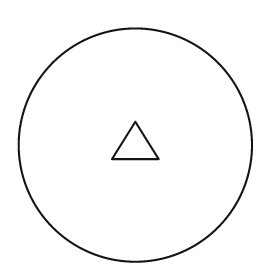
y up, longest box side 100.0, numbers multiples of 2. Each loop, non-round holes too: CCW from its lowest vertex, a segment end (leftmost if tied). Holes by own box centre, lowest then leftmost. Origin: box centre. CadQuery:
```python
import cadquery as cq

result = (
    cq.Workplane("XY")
    .moveTo(0.0, 0.0)
    .circle(50.0)
    .moveTo(-10.0, -6.0)
    .lineTo(10.0, -6.0)
    .lineTo(0.0, 10.0)
    .close()
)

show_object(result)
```